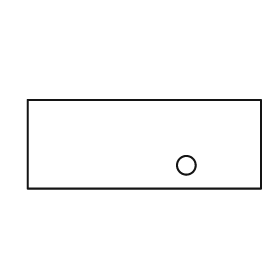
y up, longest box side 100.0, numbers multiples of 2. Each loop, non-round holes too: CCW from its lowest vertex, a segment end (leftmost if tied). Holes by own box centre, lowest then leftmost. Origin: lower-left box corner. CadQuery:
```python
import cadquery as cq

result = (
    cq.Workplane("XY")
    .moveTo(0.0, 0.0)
    .lineTo(100.0, 0.0)
    .lineTo(100.0, 38.0)
    .lineTo(0.0, 38.0)
    .close()
    .moveTo(68.0, 10.0)
    .circle(4.0)
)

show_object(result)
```